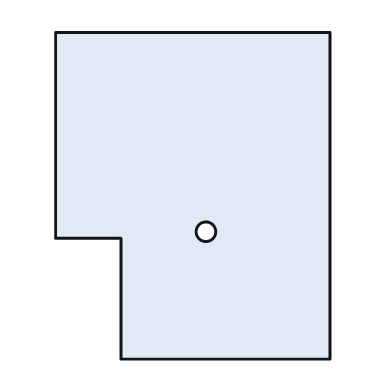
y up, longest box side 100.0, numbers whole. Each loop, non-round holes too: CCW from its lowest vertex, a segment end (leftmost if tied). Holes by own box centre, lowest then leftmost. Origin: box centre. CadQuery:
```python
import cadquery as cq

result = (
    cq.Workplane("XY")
    .moveTo(-22.0, -50.0)
    .lineTo(42.0, -50.0)
    .lineTo(42.0, 50.0)
    .lineTo(-42.0, 50.0)
    .lineTo(-42.0, -13.0)
    .lineTo(-22.0, -13.0)
    .close()
    .moveTo(4.0, -11.0)
    .circle(3.0)
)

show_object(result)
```